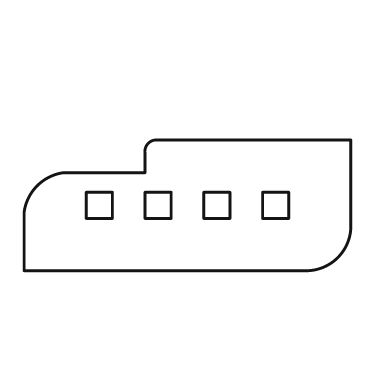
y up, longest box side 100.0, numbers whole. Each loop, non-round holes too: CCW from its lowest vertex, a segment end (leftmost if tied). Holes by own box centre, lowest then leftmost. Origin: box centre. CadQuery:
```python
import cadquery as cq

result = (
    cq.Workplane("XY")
    .moveTo(-50.0, -20.0)
    .lineTo(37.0, -20.0)
    .threePointArc((46.0, -16.0), (50.0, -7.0))
    .lineTo(50.0, 20.0)
    .lineTo(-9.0, 20.0)
    .threePointArc((-12.0, 19.0), (-13.0, 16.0))
    .lineTo(-13.0, 10.0)
    .lineTo(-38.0, 10.0)
    .threePointArc((-46.0, 6.0), (-50.0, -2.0))
    .close()
    .moveTo(-31.0, -4.0)
    .lineTo(-23.0, -4.0)
    .lineTo(-23.0, 4.0)
    .lineTo(-31.0, 4.0)
    .close()
    .moveTo(-13.0, -4.0)
    .lineTo(-5.0, -4.0)
    .lineTo(-5.0, 4.0)
    .lineTo(-13.0, 4.0)
    .close()
    .moveTo(5.0, -4.0)
    .lineTo(13.0, -4.0)
    .lineTo(13.0, 4.0)
    .lineTo(5.0, 4.0)
    .close()
    .moveTo(23.0, -4.0)
    .lineTo(31.0, -4.0)
    .lineTo(31.0, 4.0)
    .lineTo(23.0, 4.0)
    .close()
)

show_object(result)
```